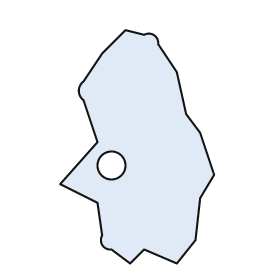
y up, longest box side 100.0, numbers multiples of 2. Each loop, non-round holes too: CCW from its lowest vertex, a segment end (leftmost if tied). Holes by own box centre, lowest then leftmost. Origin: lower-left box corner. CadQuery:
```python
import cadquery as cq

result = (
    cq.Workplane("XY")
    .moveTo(30.0, 0.0)
    .lineTo(36.0, 6.0)
    .lineTo(50.0, 0.0)
    .lineTo(58.0, 10.0)
    .lineTo(60.0, 28.0)
    .lineTo(66.0, 38.0)
    .lineTo(60.0, 56.0)
    .lineTo(54.0, 64.0)
    .lineTo(50.0, 82.0)
    .lineTo(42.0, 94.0)
    .threePointArc((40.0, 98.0), (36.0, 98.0))
    .lineTo(28.0, 100.0)
    .lineTo(18.0, 90.0)
    .lineTo(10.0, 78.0)
    .threePointArc((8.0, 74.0), (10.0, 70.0))
    .lineTo(16.0, 52.0)
    .lineTo(0.0, 34.0)
    .lineTo(16.0, 26.0)
    .lineTo(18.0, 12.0)
    .threePointArc((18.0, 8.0), (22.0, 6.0))
    .close()
    .moveTo(22.0, 42.0)
    .circle(6.0)
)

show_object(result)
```